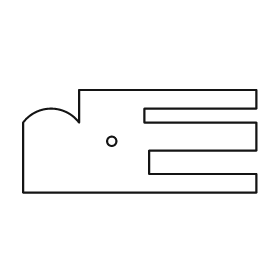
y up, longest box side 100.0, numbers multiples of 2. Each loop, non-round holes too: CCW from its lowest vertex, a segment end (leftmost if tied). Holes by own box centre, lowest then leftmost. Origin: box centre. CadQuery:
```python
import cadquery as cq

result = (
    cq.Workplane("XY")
    .moveTo(-50.0, -22.0)
    .lineTo(50.0, -22.0)
    .lineTo(50.0, -14.0)
    .lineTo(4.0, -14.0)
    .lineTo(4.0, -4.0)
    .lineTo(50.0, -4.0)
    .lineTo(50.0, 8.0)
    .lineTo(2.0, 8.0)
    .lineTo(2.0, 14.0)
    .lineTo(50.0, 14.0)
    .lineTo(50.0, 22.0)
    .lineTo(-26.0, 22.0)
    .lineTo(-26.0, 8.0)
    .threePointArc((-38.0, 14.0), (-50.0, 8.0))
    .close()
    .moveTo(-12.0, 0.0)
    .circle(2.0)
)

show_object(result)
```